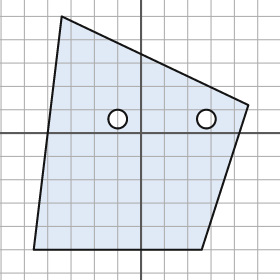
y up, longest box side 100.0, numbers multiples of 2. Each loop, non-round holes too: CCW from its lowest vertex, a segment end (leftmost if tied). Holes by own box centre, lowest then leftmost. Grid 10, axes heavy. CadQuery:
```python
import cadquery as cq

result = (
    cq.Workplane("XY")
    .moveTo(-46.0, -50.0)
    .lineTo(26.0, -50.0)
    .lineTo(46.0, 12.0)
    .lineTo(-34.0, 50.0)
    .close()
    .moveTo(-10.0, 6.0)
    .circle(4.0)
    .moveTo(28.0, 6.0)
    .circle(4.0)
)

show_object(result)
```